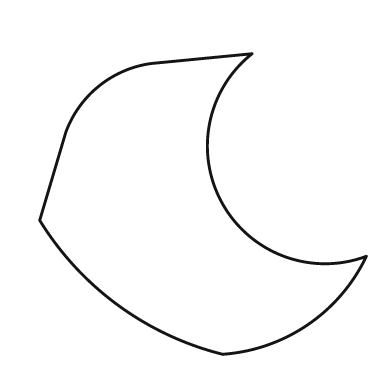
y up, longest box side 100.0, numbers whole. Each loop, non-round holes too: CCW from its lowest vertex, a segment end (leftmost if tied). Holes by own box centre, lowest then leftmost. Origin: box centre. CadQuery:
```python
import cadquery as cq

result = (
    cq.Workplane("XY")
    .moveTo(6.0, -46.0)
    .threePointArc((32.0, -37.0), (50.0, -16.0))
    .threePointArc((6.0, 0.0), (15.0, 46.0))
    .lineTo(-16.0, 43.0)
    .threePointArc((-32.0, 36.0), (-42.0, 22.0))
    .lineTo(-50.0, -5.0)
    .threePointArc((-26.0, -31.0), (6.0, -46.0))
    .close()
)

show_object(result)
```